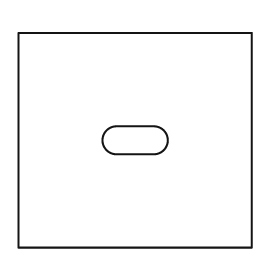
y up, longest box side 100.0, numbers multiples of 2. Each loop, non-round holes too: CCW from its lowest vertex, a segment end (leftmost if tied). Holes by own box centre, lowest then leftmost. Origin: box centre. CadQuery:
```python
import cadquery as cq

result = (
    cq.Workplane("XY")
    .moveTo(-50.0, -46.0)
    .lineTo(50.0, -46.0)
    .lineTo(50.0, 46.0)
    .lineTo(-50.0, 46.0)
    .close()
    .moveTo(-8.0, -6.0)
    .lineTo(8.0, -6.0)
    .threePointArc((14.0, 0.0), (8.0, 6.0))
    .lineTo(-8.0, 6.0)
    .threePointArc((-14.0, 0.0), (-8.0, -6.0))
    .close()
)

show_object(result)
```